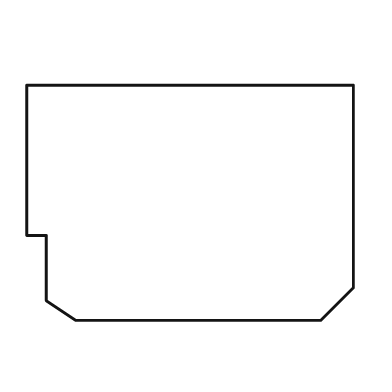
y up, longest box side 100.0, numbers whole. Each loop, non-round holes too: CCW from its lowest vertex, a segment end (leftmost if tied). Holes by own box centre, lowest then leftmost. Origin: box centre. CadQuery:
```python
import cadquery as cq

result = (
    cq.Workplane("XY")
    .moveTo(-35.0, -36.0)
    .lineTo(40.0, -36.0)
    .lineTo(50.0, -26.0)
    .lineTo(50.0, 36.0)
    .lineTo(-50.0, 36.0)
    .lineTo(-50.0, -10.0)
    .lineTo(-44.0, -10.0)
    .lineTo(-44.0, -30.0)
    .close()
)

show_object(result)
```